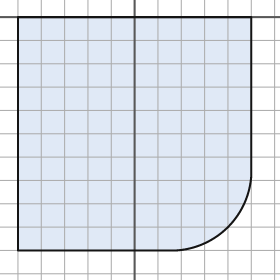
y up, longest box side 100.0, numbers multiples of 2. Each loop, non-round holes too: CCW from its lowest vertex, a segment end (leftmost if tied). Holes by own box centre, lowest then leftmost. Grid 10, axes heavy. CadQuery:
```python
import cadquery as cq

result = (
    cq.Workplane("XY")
    .moveTo(-50.0, -100.0)
    .lineTo(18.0, -100.0)
    .threePointArc((40.0, -90.0), (50.0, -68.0))
    .lineTo(50.0, 0.0)
    .lineTo(-50.0, 0.0)
    .close()
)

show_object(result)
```